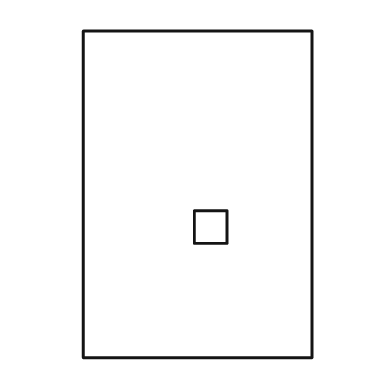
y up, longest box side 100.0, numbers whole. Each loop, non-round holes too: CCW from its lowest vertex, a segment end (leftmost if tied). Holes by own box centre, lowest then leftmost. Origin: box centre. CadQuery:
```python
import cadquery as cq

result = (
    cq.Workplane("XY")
    .moveTo(-35.0, -50.0)
    .lineTo(35.0, -50.0)
    .lineTo(35.0, 50.0)
    .lineTo(-35.0, 50.0)
    .close()
    .moveTo(-1.0, -15.0)
    .lineTo(9.0, -15.0)
    .lineTo(9.0, -5.0)
    .lineTo(-1.0, -5.0)
    .close()
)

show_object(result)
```